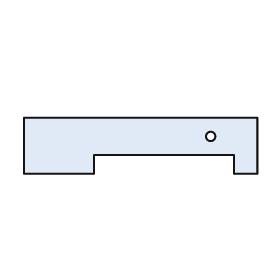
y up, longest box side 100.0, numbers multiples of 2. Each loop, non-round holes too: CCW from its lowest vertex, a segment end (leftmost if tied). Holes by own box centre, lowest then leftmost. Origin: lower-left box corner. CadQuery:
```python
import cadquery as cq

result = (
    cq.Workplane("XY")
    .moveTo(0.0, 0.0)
    .lineTo(30.0, 0.0)
    .lineTo(30.0, 8.0)
    .lineTo(90.0, 8.0)
    .lineTo(90.0, 0.0)
    .lineTo(100.0, 0.0)
    .lineTo(100.0, 24.0)
    .lineTo(0.0, 24.0)
    .close()
    .moveTo(80.0, 16.0)
    .circle(2.0)
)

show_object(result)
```